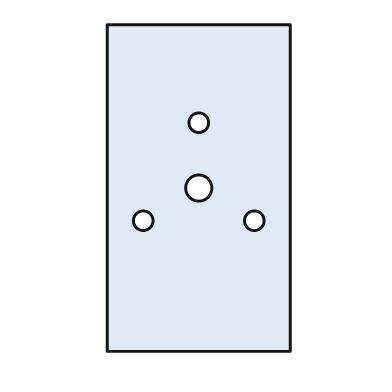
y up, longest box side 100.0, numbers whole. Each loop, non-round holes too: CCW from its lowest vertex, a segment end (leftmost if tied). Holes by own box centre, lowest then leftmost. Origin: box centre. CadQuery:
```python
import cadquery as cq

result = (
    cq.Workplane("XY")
    .moveTo(-28.0, -50.0)
    .lineTo(28.0, -50.0)
    .lineTo(28.0, 50.0)
    .lineTo(-28.0, 50.0)
    .close()
    .moveTo(-17.0, -10.0)
    .circle(3.0)
    .moveTo(17.0, -10.0)
    .circle(3.0)
    .moveTo(0.0, 0.0)
    .circle(4.0)
    .moveTo(0.0, 20.0)
    .circle(3.0)
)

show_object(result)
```